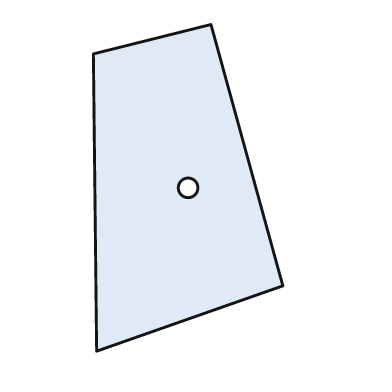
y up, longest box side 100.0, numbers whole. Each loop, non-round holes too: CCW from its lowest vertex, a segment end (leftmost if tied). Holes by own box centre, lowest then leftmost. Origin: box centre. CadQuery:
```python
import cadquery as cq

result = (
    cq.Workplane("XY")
    .moveTo(-28.0, -50.0)
    .lineTo(29.0, -30.0)
    .lineTo(7.0, 50.0)
    .lineTo(-29.0, 41.0)
    .close()
    .moveTo(0.0, 0.0)
    .circle(3.0)
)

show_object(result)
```